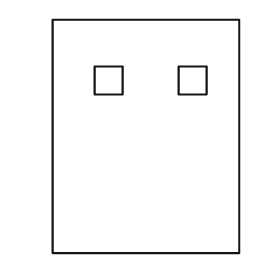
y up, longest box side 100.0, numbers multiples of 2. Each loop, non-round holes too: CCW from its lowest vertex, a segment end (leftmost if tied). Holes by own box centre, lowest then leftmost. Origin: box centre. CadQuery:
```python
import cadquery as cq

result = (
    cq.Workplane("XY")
    .moveTo(-40.0, -50.0)
    .lineTo(40.0, -50.0)
    .lineTo(40.0, 50.0)
    .lineTo(-40.0, 50.0)
    .close()
    .moveTo(-22.0, 18.0)
    .lineTo(-10.0, 18.0)
    .lineTo(-10.0, 30.0)
    .lineTo(-22.0, 30.0)
    .close()
    .moveTo(14.0, 18.0)
    .lineTo(26.0, 18.0)
    .lineTo(26.0, 30.0)
    .lineTo(14.0, 30.0)
    .close()
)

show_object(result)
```